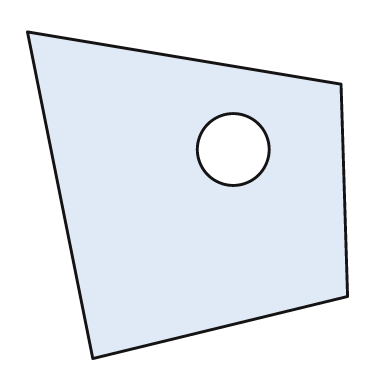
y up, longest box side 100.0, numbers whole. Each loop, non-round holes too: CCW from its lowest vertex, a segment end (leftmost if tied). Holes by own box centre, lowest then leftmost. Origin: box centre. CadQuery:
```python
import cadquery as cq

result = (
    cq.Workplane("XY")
    .moveTo(-29.0, -50.0)
    .lineTo(49.0, -31.0)
    .lineTo(47.0, 34.0)
    .lineTo(-49.0, 50.0)
    .close()
    .moveTo(14.0, 14.0)
    .circle(11.0)
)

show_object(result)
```